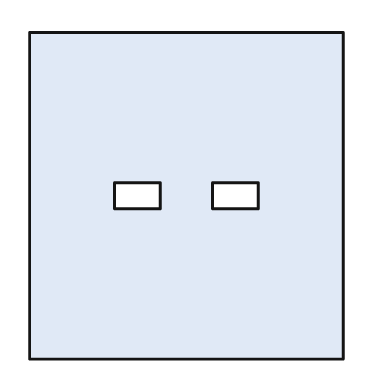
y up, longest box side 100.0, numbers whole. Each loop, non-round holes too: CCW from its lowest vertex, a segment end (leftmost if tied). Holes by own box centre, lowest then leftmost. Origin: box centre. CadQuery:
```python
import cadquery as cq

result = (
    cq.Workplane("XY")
    .moveTo(-48.0, -50.0)
    .lineTo(48.0, -50.0)
    .lineTo(48.0, 50.0)
    .lineTo(-48.0, 50.0)
    .close()
    .moveTo(-22.0, -4.0)
    .lineTo(-8.0, -4.0)
    .lineTo(-8.0, 4.0)
    .lineTo(-22.0, 4.0)
    .close()
    .moveTo(8.0, -4.0)
    .lineTo(22.0, -4.0)
    .lineTo(22.0, 4.0)
    .lineTo(8.0, 4.0)
    .close()
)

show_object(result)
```